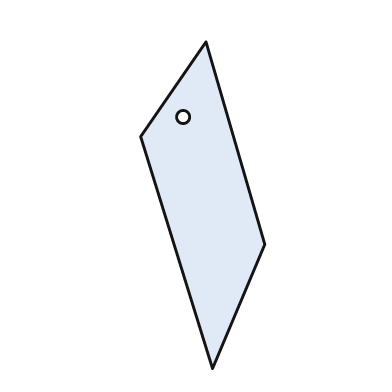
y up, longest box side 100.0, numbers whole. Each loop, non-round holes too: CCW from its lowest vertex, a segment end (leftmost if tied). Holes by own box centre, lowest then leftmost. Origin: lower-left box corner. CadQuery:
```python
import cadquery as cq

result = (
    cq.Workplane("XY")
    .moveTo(22.0, 0.0)
    .lineTo(38.0, 38.0)
    .lineTo(20.0, 100.0)
    .lineTo(0.0, 71.0)
    .close()
    .moveTo(13.0, 77.0)
    .circle(2.0)
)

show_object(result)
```